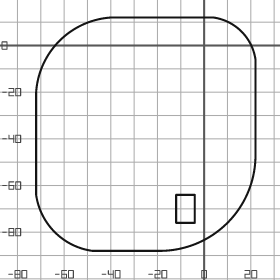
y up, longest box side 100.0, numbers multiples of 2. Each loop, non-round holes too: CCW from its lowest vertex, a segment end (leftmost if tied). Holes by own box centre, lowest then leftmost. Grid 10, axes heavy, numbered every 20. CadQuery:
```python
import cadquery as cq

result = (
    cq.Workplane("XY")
    .moveTo(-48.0, -88.0)
    .lineTo(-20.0, -88.0)
    .threePointArc((10.0, -76.0), (22.0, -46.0))
    .lineTo(22.0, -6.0)
    .threePointArc((16.0, 6.0), (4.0, 12.0))
    .lineTo(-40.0, 12.0)
    .threePointArc((-62.0, 2.0), (-72.0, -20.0))
    .lineTo(-72.0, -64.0)
    .threePointArc((-64.0, -80.0), (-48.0, -88.0))
    .close()
    .moveTo(-12.0, -76.0)
    .lineTo(-4.0, -76.0)
    .lineTo(-4.0, -64.0)
    .lineTo(-12.0, -64.0)
    .close()
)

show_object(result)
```